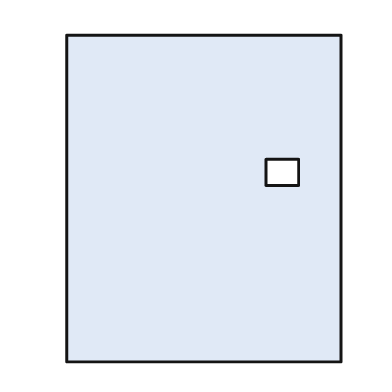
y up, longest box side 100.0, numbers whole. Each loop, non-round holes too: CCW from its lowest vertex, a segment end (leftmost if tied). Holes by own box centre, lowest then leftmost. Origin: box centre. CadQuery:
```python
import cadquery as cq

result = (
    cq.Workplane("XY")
    .moveTo(-42.0, -50.0)
    .lineTo(42.0, -50.0)
    .lineTo(42.0, 50.0)
    .lineTo(-42.0, 50.0)
    .close()
    .moveTo(19.0, 4.0)
    .lineTo(29.0, 4.0)
    .lineTo(29.0, 12.0)
    .lineTo(19.0, 12.0)
    .close()
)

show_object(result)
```